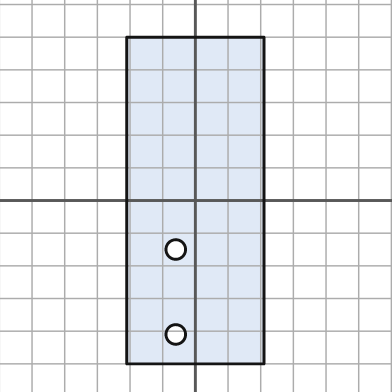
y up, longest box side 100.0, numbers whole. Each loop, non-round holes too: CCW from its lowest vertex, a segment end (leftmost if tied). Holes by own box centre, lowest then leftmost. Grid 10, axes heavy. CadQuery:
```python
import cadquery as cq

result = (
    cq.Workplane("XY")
    .moveTo(-21.0, -50.0)
    .lineTo(21.0, -50.0)
    .lineTo(21.0, 50.0)
    .lineTo(-21.0, 50.0)
    .close()
    .moveTo(-6.0, -41.0)
    .circle(3.0)
    .moveTo(-6.0, -15.0)
    .circle(3.0)
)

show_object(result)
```